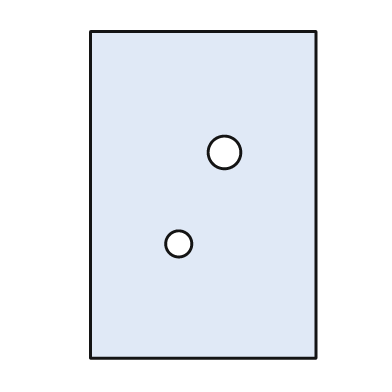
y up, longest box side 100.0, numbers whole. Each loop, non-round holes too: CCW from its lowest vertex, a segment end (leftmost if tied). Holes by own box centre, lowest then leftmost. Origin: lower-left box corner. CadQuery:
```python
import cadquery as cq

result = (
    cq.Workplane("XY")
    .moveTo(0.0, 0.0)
    .lineTo(69.0, 0.0)
    .lineTo(69.0, 100.0)
    .lineTo(0.0, 100.0)
    .close()
    .moveTo(27.0, 35.0)
    .circle(4.0)
    .moveTo(41.0, 63.0)
    .circle(5.0)
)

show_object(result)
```